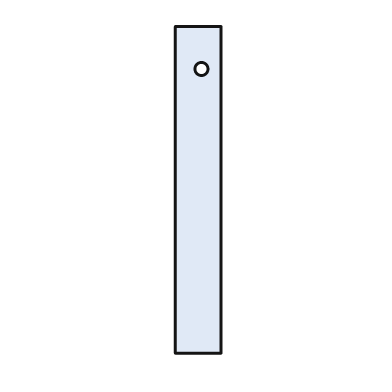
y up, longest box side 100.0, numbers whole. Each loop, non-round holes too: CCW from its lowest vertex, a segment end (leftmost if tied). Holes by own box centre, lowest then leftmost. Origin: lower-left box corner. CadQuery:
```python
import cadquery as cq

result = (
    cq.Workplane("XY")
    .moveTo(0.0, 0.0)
    .lineTo(14.0, 0.0)
    .lineTo(14.0, 100.0)
    .lineTo(0.0, 100.0)
    .close()
    .moveTo(8.0, 87.0)
    .circle(2.0)
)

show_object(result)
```